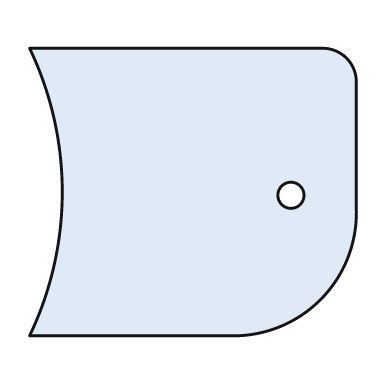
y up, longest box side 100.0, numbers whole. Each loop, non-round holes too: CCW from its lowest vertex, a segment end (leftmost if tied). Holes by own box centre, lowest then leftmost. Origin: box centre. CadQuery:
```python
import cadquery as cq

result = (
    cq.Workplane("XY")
    .moveTo(-50.0, -44.0)
    .lineTo(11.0, -44.0)
    .threePointArc((39.0, -33.0), (50.0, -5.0))
    .lineTo(50.0, 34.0)
    .threePointArc((47.0, 41.0), (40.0, 44.0))
    .lineTo(-50.0, 44.0)
    .threePointArc((-40.0, 0.0), (-50.0, -44.0))
    .close()
    .moveTo(30.0, -1.0)
    .circle(4.0)
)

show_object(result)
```